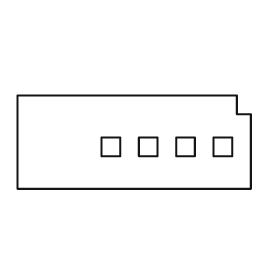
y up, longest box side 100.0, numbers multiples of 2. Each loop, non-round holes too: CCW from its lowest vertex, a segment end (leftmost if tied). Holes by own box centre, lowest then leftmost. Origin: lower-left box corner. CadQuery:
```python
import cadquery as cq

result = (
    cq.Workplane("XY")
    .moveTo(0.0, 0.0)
    .lineTo(100.0, 0.0)
    .lineTo(100.0, 32.0)
    .lineTo(94.0, 32.0)
    .lineTo(94.0, 40.0)
    .lineTo(0.0, 40.0)
    .close()
    .moveTo(36.0, 14.0)
    .lineTo(44.0, 14.0)
    .lineTo(44.0, 22.0)
    .lineTo(36.0, 22.0)
    .close()
    .moveTo(52.0, 14.0)
    .lineTo(60.0, 14.0)
    .lineTo(60.0, 22.0)
    .lineTo(52.0, 22.0)
    .close()
    .moveTo(68.0, 14.0)
    .lineTo(76.0, 14.0)
    .lineTo(76.0, 22.0)
    .lineTo(68.0, 22.0)
    .close()
    .moveTo(84.0, 14.0)
    .lineTo(92.0, 14.0)
    .lineTo(92.0, 22.0)
    .lineTo(84.0, 22.0)
    .close()
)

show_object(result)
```